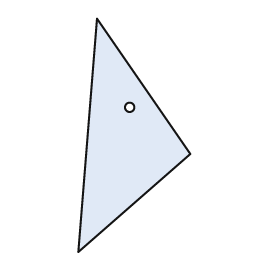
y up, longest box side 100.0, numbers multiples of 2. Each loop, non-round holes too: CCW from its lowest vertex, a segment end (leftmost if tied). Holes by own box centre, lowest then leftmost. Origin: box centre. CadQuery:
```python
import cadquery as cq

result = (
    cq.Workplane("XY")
    .moveTo(-24.0, -50.0)
    .lineTo(24.0, -8.0)
    .lineTo(-16.0, 50.0)
    .close()
    .moveTo(-2.0, 12.0)
    .circle(2.0)
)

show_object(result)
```